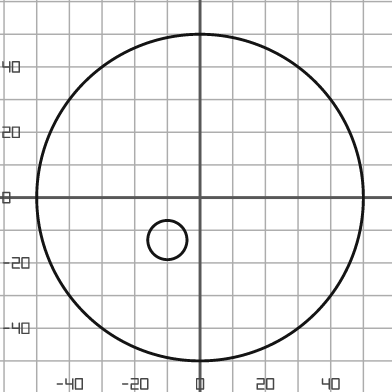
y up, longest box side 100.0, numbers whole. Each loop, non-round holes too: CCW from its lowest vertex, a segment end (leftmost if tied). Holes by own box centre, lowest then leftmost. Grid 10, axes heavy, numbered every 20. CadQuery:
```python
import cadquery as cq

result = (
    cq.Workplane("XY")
    .moveTo(0.0, 0.0)
    .circle(50.0)
    .moveTo(-10.0, -13.0)
    .circle(6.0)
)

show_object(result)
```